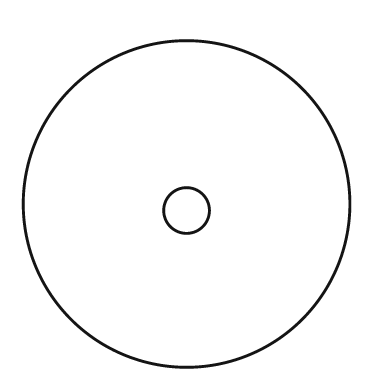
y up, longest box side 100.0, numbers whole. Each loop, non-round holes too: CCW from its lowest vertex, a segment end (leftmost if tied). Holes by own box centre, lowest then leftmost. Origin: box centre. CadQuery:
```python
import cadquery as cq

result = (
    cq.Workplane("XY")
    .moveTo(0.0, 0.0)
    .circle(50.0)
    .moveTo(0.0, -2.0)
    .circle(7.0)
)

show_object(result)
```